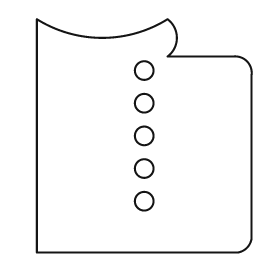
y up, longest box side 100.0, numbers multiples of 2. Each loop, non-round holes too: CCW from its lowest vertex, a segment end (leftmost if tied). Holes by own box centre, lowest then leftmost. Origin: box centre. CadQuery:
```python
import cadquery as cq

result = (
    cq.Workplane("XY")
    .moveTo(-46.0, -50.0)
    .lineTo(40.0, -50.0)
    .threePointArc((44.0, -48.0), (46.0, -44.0))
    .lineTo(46.0, 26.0)
    .threePointArc((44.0, 32.0), (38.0, 34.0))
    .lineTo(10.0, 34.0)
    .threePointArc((14.0, 42.0), (10.0, 50.0))
    .threePointArc((-18.0, 42.0), (-46.0, 50.0))
    .close()
    .moveTo(0.0, -28.0)
    .circle(4.0)
    .moveTo(0.0, -14.0)
    .circle(4.0)
    .moveTo(0.0, 0.0)
    .circle(4.0)
    .moveTo(0.0, 14.0)
    .circle(4.0)
    .moveTo(0.0, 28.0)
    .circle(4.0)
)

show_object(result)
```